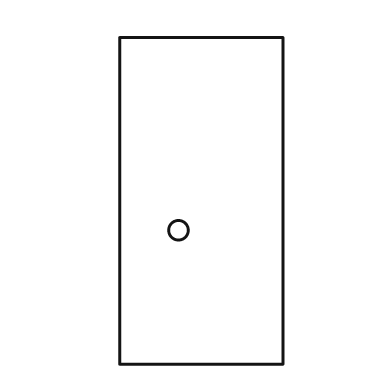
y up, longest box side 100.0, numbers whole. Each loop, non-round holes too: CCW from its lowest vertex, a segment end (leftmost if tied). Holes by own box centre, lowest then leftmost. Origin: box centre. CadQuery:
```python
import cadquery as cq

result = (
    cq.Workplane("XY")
    .moveTo(-25.0, -50.0)
    .lineTo(25.0, -50.0)
    .lineTo(25.0, 50.0)
    .lineTo(-25.0, 50.0)
    .close()
    .moveTo(-7.0, -9.0)
    .circle(3.0)
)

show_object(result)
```